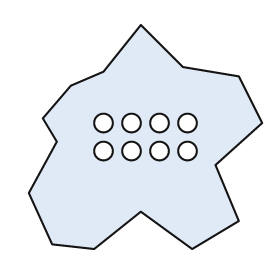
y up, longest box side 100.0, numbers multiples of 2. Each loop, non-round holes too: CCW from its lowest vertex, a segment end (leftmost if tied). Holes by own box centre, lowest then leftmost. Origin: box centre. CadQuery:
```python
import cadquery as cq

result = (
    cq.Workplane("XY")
    .moveTo(-22.0, -48.0)
    .lineTo(-2.0, -32.0)
    .lineTo(20.0, -48.0)
    .lineTo(40.0, -36.0)
    .lineTo(30.0, -12.0)
    .lineTo(50.0, 6.0)
    .lineTo(40.0, 26.0)
    .lineTo(16.0, 30.0)
    .lineTo(-2.0, 48.0)
    .lineTo(-18.0, 28.0)
    .lineTo(-32.0, 22.0)
    .lineTo(-44.0, 8.0)
    .lineTo(-38.0, -2.0)
    .lineTo(-50.0, -24.0)
    .lineTo(-40.0, -46.0)
    .close()
    .moveTo(-18.0, -6.0)
    .circle(4.0)
    .moveTo(-6.0, -6.0)
    .circle(4.0)
    .moveTo(6.0, -6.0)
    .circle(4.0)
    .moveTo(18.0, -6.0)
    .circle(4.0)
    .moveTo(-18.0, 6.0)
    .circle(4.0)
    .moveTo(-6.0, 6.0)
    .circle(4.0)
    .moveTo(6.0, 6.0)
    .circle(4.0)
    .moveTo(18.0, 6.0)
    .circle(4.0)
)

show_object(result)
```